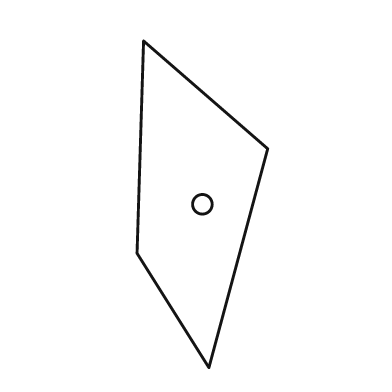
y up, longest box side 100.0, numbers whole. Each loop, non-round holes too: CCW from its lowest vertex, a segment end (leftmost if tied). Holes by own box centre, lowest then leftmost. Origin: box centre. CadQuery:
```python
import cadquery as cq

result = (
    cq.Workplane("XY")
    .moveTo(2.0, -50.0)
    .lineTo(20.0, 17.0)
    .lineTo(-18.0, 50.0)
    .lineTo(-20.0, -15.0)
    .close()
    .moveTo(0.0, 0.0)
    .circle(3.0)
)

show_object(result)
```